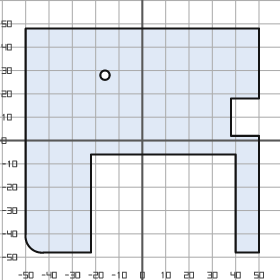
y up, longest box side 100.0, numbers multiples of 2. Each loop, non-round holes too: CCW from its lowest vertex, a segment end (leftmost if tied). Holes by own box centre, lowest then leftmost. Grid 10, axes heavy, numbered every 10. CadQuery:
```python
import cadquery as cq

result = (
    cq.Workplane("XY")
    .moveTo(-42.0, -48.0)
    .lineTo(-22.0, -48.0)
    .lineTo(-22.0, -6.0)
    .lineTo(40.0, -6.0)
    .lineTo(40.0, -48.0)
    .lineTo(50.0, -48.0)
    .lineTo(50.0, 2.0)
    .lineTo(38.0, 2.0)
    .lineTo(38.0, 18.0)
    .lineTo(50.0, 18.0)
    .lineTo(50.0, 48.0)
    .lineTo(-50.0, 48.0)
    .lineTo(-50.0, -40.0)
    .threePointArc((-48.0, -46.0), (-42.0, -48.0))
    .close()
    .moveTo(-16.0, 28.0)
    .circle(2.0)
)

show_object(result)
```